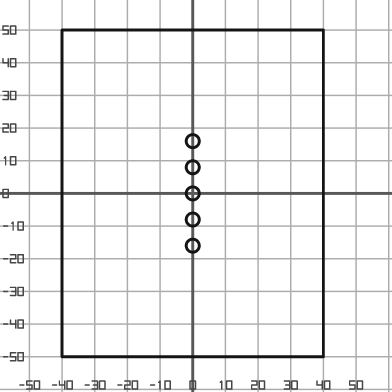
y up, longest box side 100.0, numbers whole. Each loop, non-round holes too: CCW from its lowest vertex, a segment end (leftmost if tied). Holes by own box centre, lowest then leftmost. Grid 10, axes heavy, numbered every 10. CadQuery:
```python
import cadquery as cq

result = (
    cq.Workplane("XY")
    .moveTo(-40.0, -50.0)
    .lineTo(40.0, -50.0)
    .lineTo(40.0, 50.0)
    .lineTo(-40.0, 50.0)
    .close()
    .moveTo(0.0, -16.0)
    .circle(2.0)
    .moveTo(0.0, -8.0)
    .circle(2.0)
    .moveTo(0.0, 0.0)
    .circle(2.0)
    .moveTo(0.0, 8.0)
    .circle(2.0)
    .moveTo(0.0, 16.0)
    .circle(2.0)
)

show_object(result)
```